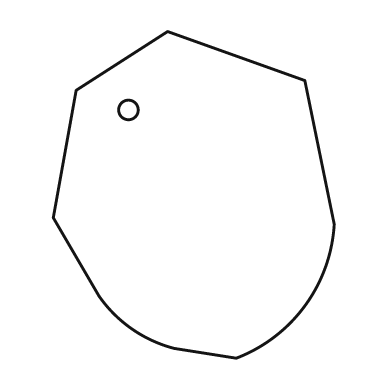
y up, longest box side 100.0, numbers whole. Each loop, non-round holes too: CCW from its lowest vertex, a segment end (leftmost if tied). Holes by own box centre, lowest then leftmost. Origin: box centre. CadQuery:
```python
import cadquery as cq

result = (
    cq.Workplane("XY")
    .moveTo(13.0, -50.0)
    .threePointArc((34.0, -34.0), (43.0, -9.0))
    .lineTo(34.0, 35.0)
    .lineTo(-8.0, 50.0)
    .lineTo(-36.0, 32.0)
    .lineTo(-43.0, -7.0)
    .lineTo(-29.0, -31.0)
    .threePointArc((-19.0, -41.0), (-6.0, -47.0))
    .close()
    .moveTo(-20.0, 26.0)
    .circle(3.0)
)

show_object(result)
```